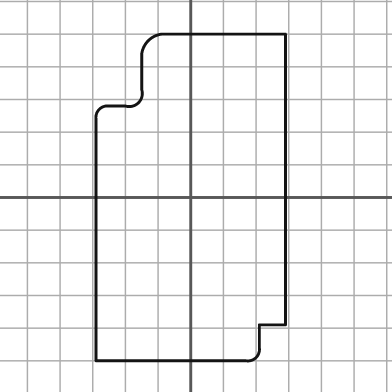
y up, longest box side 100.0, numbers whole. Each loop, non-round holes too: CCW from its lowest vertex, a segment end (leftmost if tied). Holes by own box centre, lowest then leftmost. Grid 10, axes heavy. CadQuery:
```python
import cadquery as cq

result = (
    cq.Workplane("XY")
    .moveTo(-29.0, -50.0)
    .lineTo(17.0, -50.0)
    .threePointArc((20.0, -49.0), (21.0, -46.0))
    .lineTo(21.0, -39.0)
    .lineTo(29.0, -39.0)
    .lineTo(29.0, 50.0)
    .lineTo(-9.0, 50.0)
    .threePointArc((-13.0, 48.0), (-15.0, 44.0))
    .lineTo(-15.0, 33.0)
    .threePointArc((-16.0, 29.0), (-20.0, 28.0))
    .lineTo(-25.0, 28.0)
    .threePointArc((-28.0, 27.0), (-29.0, 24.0))
    .close()
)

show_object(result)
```